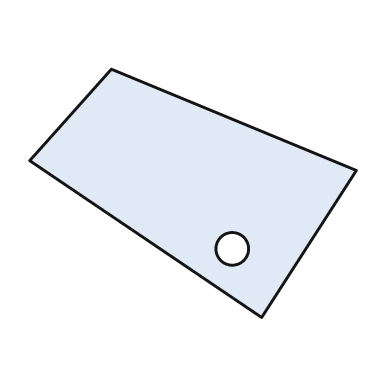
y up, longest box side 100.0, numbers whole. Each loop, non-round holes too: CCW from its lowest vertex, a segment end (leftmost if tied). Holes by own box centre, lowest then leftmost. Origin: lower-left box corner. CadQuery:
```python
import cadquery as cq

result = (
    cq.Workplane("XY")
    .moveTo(71.0, 0.0)
    .lineTo(100.0, 45.0)
    .lineTo(25.0, 76.0)
    .lineTo(0.0, 48.0)
    .close()
    .moveTo(62.0, 21.0)
    .circle(5.0)
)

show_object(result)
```